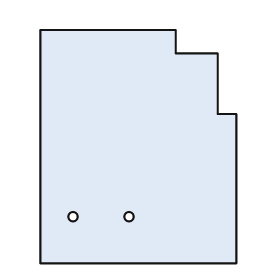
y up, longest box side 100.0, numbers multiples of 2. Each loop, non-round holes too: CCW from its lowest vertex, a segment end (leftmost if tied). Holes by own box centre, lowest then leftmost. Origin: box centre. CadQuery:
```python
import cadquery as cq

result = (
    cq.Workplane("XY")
    .moveTo(-42.0, -50.0)
    .lineTo(42.0, -50.0)
    .lineTo(42.0, 14.0)
    .lineTo(34.0, 14.0)
    .lineTo(34.0, 40.0)
    .lineTo(16.0, 40.0)
    .lineTo(16.0, 50.0)
    .lineTo(-42.0, 50.0)
    .close()
    .moveTo(-28.0, -30.0)
    .circle(2.0)
    .moveTo(-4.0, -30.0)
    .circle(2.0)
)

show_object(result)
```